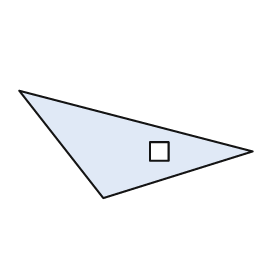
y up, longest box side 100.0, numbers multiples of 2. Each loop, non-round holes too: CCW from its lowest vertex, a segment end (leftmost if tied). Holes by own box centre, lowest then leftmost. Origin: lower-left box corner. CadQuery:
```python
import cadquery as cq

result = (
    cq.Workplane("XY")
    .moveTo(36.0, 0.0)
    .lineTo(100.0, 20.0)
    .lineTo(0.0, 46.0)
    .close()
    .moveTo(56.0, 16.0)
    .lineTo(64.0, 16.0)
    .lineTo(64.0, 24.0)
    .lineTo(56.0, 24.0)
    .close()
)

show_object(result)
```